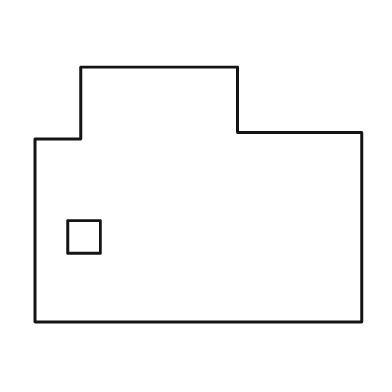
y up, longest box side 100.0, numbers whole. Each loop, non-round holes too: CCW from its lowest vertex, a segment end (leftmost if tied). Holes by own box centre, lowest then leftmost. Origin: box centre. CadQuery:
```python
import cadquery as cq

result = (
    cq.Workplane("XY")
    .moveTo(-50.0, -39.0)
    .lineTo(50.0, -39.0)
    .lineTo(50.0, 19.0)
    .lineTo(12.0, 19.0)
    .lineTo(12.0, 39.0)
    .lineTo(-36.0, 39.0)
    .lineTo(-36.0, 17.0)
    .lineTo(-50.0, 17.0)
    .close()
    .moveTo(-40.0, -18.0)
    .lineTo(-30.0, -18.0)
    .lineTo(-30.0, -8.0)
    .lineTo(-40.0, -8.0)
    .close()
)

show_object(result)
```